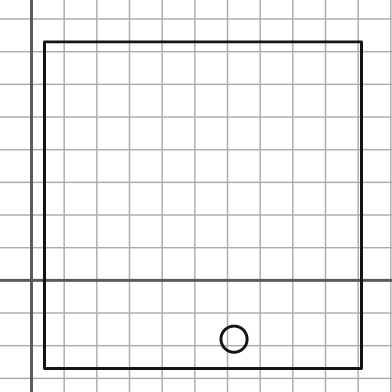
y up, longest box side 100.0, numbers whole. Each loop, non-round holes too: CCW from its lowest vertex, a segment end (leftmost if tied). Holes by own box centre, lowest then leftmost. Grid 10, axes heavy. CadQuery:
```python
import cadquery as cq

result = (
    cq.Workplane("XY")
    .moveTo(4.0, -27.0)
    .lineTo(101.0, -27.0)
    .lineTo(101.0, 73.0)
    .lineTo(4.0, 73.0)
    .close()
    .moveTo(62.0, -18.0)
    .circle(4.0)
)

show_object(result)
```